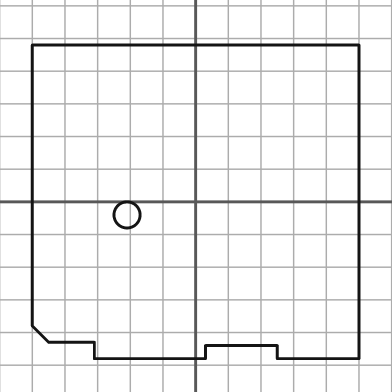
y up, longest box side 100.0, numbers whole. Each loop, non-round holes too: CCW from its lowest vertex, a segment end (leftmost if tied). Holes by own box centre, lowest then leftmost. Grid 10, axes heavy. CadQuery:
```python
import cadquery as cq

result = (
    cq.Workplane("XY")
    .moveTo(-31.0, -48.0)
    .lineTo(3.0, -48.0)
    .lineTo(3.0, -44.0)
    .lineTo(25.0, -44.0)
    .lineTo(25.0, -48.0)
    .lineTo(50.0, -48.0)
    .lineTo(50.0, 48.0)
    .lineTo(-50.0, 48.0)
    .lineTo(-50.0, -38.0)
    .lineTo(-45.0, -43.0)
    .lineTo(-31.0, -43.0)
    .close()
    .moveTo(-21.0, -4.0)
    .circle(4.0)
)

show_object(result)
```